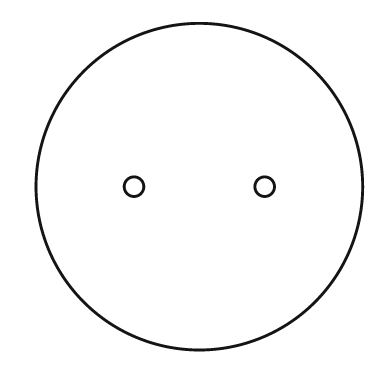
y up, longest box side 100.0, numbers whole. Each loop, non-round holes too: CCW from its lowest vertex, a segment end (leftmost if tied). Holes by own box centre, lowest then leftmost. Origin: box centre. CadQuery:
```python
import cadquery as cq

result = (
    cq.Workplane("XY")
    .moveTo(0.0, 0.0)
    .circle(50.0)
    .moveTo(-20.0, 0.0)
    .circle(3.0)
    .moveTo(20.0, 0.0)
    .circle(3.0)
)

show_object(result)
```